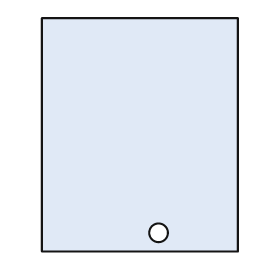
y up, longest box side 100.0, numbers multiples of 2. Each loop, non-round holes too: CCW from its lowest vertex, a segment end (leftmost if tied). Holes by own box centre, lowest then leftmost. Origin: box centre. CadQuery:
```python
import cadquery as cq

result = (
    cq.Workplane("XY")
    .moveTo(-42.0, -50.0)
    .lineTo(42.0, -50.0)
    .lineTo(42.0, 50.0)
    .lineTo(-42.0, 50.0)
    .close()
    .moveTo(8.0, -42.0)
    .circle(4.0)
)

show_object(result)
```